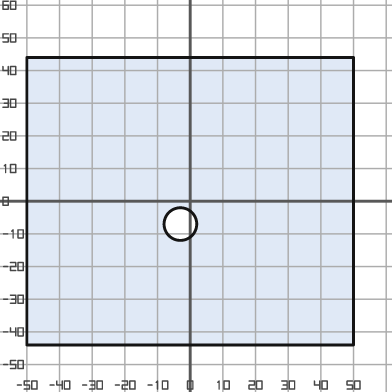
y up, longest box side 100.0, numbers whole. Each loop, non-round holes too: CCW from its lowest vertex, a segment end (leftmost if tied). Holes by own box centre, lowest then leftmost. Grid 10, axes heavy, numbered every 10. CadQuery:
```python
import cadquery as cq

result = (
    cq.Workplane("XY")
    .moveTo(-50.0, -44.0)
    .lineTo(50.0, -44.0)
    .lineTo(50.0, 44.0)
    .lineTo(-50.0, 44.0)
    .close()
    .moveTo(-3.0, -7.0)
    .circle(5.0)
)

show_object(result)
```